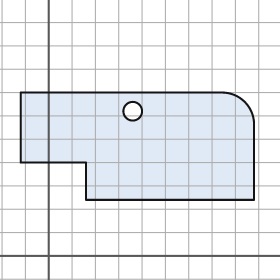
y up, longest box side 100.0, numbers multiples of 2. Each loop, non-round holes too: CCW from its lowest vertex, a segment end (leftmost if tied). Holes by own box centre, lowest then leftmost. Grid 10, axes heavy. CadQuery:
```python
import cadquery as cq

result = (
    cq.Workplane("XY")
    .moveTo(16.0, 24.0)
    .lineTo(88.0, 24.0)
    .lineTo(88.0, 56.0)
    .threePointArc((84.0, 66.0), (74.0, 70.0))
    .lineTo(-12.0, 70.0)
    .lineTo(-12.0, 40.0)
    .lineTo(16.0, 40.0)
    .close()
    .moveTo(36.0, 62.0)
    .circle(4.0)
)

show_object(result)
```